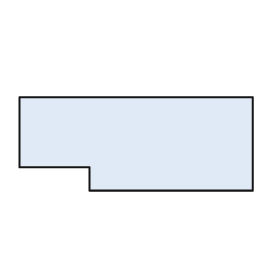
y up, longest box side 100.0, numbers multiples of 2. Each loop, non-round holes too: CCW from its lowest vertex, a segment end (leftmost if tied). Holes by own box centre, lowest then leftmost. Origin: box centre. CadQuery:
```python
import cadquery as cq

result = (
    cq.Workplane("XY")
    .moveTo(-20.0, -20.0)
    .lineTo(50.0, -20.0)
    .lineTo(50.0, 20.0)
    .lineTo(-50.0, 20.0)
    .lineTo(-50.0, -10.0)
    .lineTo(-20.0, -10.0)
    .close()
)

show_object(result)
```